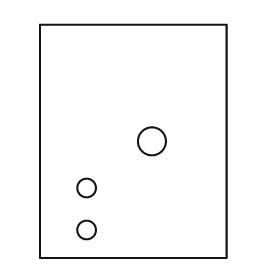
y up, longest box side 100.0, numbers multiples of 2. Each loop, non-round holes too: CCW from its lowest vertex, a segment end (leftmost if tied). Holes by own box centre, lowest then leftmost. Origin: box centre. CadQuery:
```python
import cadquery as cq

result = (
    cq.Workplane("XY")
    .moveTo(-40.0, -50.0)
    .lineTo(40.0, -50.0)
    .lineTo(40.0, 50.0)
    .lineTo(-40.0, 50.0)
    .close()
    .moveTo(-20.0, -38.0)
    .circle(4.0)
    .moveTo(-20.0, -20.0)
    .circle(4.0)
    .moveTo(8.0, 0.0)
    .circle(6.0)
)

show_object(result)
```